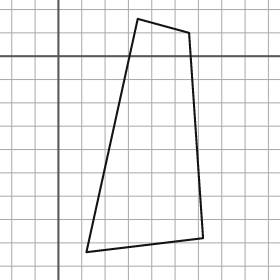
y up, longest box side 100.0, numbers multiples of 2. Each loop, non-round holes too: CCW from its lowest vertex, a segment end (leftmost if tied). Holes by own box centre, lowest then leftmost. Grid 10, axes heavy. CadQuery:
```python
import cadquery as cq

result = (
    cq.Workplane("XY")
    .moveTo(12.0, -84.0)
    .lineTo(62.0, -78.0)
    .lineTo(56.0, 10.0)
    .lineTo(34.0, 16.0)
    .close()
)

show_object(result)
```